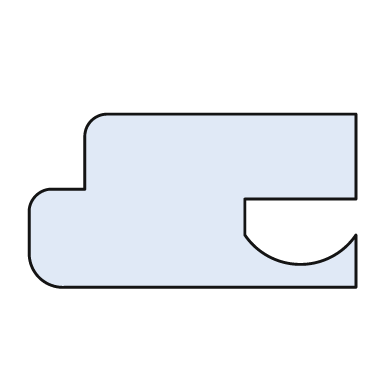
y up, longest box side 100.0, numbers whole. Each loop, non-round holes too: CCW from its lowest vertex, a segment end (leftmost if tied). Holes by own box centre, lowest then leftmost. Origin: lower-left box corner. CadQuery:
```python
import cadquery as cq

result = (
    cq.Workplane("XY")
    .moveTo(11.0, 0.0)
    .lineTo(100.0, 0.0)
    .lineTo(100.0, 16.0)
    .threePointArc((83.0, 7.0), (66.0, 16.0))
    .lineTo(66.0, 27.0)
    .lineTo(100.0, 27.0)
    .lineTo(100.0, 53.0)
    .lineTo(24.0, 53.0)
    .threePointArc((19.0, 51.0), (17.0, 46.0))
    .lineTo(17.0, 30.0)
    .lineTo(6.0, 30.0)
    .threePointArc((2.0, 28.0), (0.0, 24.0))
    .lineTo(0.0, 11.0)
    .threePointArc((3.0, 3.0), (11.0, 0.0))
    .close()
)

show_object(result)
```